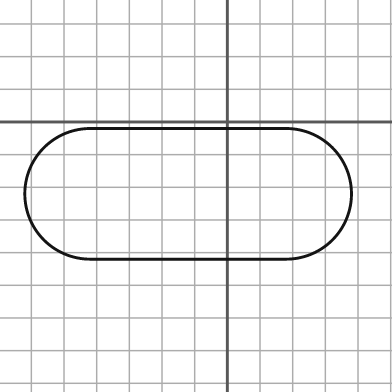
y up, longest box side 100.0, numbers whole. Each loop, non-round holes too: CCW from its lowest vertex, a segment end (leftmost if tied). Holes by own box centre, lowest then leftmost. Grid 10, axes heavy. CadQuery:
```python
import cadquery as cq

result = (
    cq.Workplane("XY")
    .moveTo(-42.0, -42.0)
    .lineTo(18.0, -42.0)
    .threePointArc((38.0, -22.0), (18.0, -2.0))
    .lineTo(-42.0, -2.0)
    .threePointArc((-62.0, -22.0), (-42.0, -42.0))
    .close()
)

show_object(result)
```